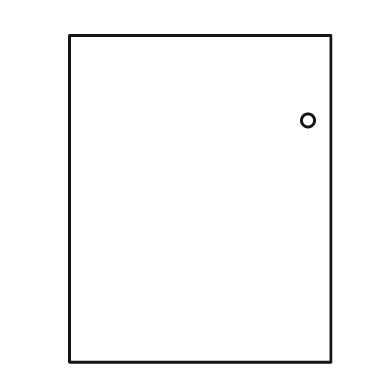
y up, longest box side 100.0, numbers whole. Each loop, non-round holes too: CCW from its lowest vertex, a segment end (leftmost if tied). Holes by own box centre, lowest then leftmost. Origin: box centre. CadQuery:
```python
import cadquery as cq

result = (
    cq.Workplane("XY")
    .moveTo(-40.0, -50.0)
    .lineTo(40.0, -50.0)
    .lineTo(40.0, 50.0)
    .lineTo(-40.0, 50.0)
    .close()
    .moveTo(33.0, 24.0)
    .circle(2.0)
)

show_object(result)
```